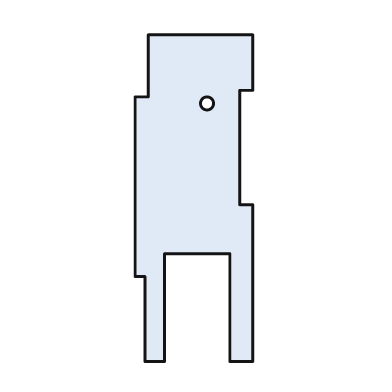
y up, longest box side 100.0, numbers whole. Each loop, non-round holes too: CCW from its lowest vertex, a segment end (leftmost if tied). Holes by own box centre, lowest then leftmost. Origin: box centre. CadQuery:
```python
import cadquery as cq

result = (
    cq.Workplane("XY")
    .moveTo(-15.0, -50.0)
    .lineTo(-9.0, -50.0)
    .lineTo(-9.0, -17.0)
    .lineTo(11.0, -17.0)
    .lineTo(11.0, -50.0)
    .lineTo(18.0, -50.0)
    .lineTo(18.0, -2.0)
    .lineTo(14.0, -2.0)
    .lineTo(14.0, 33.0)
    .lineTo(18.0, 33.0)
    .lineTo(18.0, 50.0)
    .lineTo(-14.0, 50.0)
    .lineTo(-14.0, 31.0)
    .lineTo(-18.0, 31.0)
    .lineTo(-18.0, -24.0)
    .lineTo(-15.0, -24.0)
    .close()
    .moveTo(4.0, 29.0)
    .circle(2.0)
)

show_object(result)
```